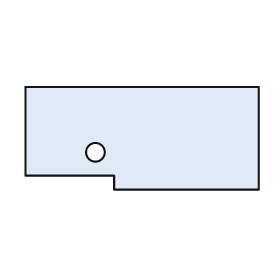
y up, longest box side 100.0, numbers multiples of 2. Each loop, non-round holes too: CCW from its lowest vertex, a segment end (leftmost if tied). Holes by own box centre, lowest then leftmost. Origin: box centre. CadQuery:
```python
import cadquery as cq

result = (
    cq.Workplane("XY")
    .moveTo(-12.0, -22.0)
    .lineTo(50.0, -22.0)
    .lineTo(50.0, 22.0)
    .lineTo(-50.0, 22.0)
    .lineTo(-50.0, -16.0)
    .lineTo(-12.0, -16.0)
    .close()
    .moveTo(-20.0, -6.0)
    .circle(4.0)
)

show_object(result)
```